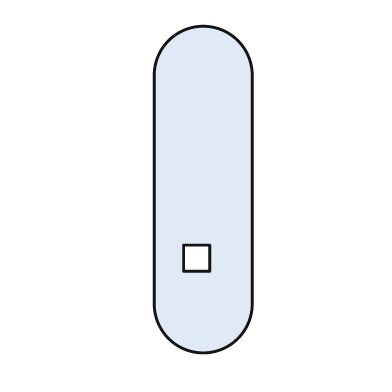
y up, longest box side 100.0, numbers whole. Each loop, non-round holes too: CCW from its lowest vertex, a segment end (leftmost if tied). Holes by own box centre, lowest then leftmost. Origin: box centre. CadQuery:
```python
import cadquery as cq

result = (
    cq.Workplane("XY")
    .moveTo(-15.0, -35.0)
    .threePointArc((0.0, -50.0), (15.0, -35.0))
    .lineTo(15.0, 35.0)
    .threePointArc((0.0, 50.0), (-15.0, 35.0))
    .close()
    .moveTo(-6.0, -25.0)
    .lineTo(2.0, -25.0)
    .lineTo(2.0, -17.0)
    .lineTo(-6.0, -17.0)
    .close()
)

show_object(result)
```